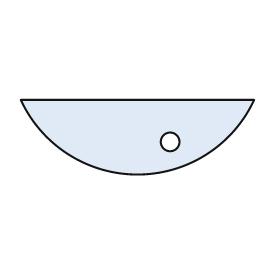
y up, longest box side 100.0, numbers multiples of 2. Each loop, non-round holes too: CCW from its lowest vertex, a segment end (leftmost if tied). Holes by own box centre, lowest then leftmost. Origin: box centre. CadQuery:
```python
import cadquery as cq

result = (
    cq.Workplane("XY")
    .moveTo(-50.0, 16.0)
    .threePointArc((0.0, -16.0), (50.0, 16.0))
    .close()
    .moveTo(14.0, -2.0)
    .circle(4.0)
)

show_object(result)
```